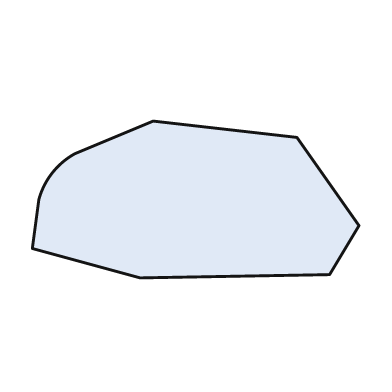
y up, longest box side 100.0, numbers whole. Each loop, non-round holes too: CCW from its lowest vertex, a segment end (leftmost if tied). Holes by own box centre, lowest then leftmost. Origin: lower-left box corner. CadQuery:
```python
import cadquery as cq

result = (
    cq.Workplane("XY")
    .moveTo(33.0, 0.0)
    .lineTo(91.0, 1.0)
    .lineTo(100.0, 16.0)
    .lineTo(81.0, 43.0)
    .lineTo(37.0, 48.0)
    .lineTo(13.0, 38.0)
    .threePointArc((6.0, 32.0), (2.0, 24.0))
    .lineTo(0.0, 9.0)
    .close()
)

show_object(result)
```